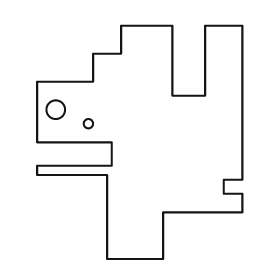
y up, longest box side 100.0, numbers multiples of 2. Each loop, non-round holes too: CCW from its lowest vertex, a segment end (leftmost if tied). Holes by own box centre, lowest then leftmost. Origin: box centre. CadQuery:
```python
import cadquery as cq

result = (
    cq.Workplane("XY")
    .moveTo(-14.0, -50.0)
    .lineTo(10.0, -50.0)
    .lineTo(10.0, -30.0)
    .lineTo(44.0, -30.0)
    .lineTo(44.0, -22.0)
    .lineTo(36.0, -22.0)
    .lineTo(36.0, -16.0)
    .lineTo(44.0, -16.0)
    .lineTo(44.0, 50.0)
    .lineTo(28.0, 50.0)
    .lineTo(28.0, 20.0)
    .lineTo(14.0, 20.0)
    .lineTo(14.0, 50.0)
    .lineTo(-8.0, 50.0)
    .lineTo(-8.0, 38.0)
    .lineTo(-20.0, 38.0)
    .lineTo(-20.0, 26.0)
    .lineTo(-44.0, 26.0)
    .lineTo(-44.0, 0.0)
    .lineTo(-12.0, 0.0)
    .lineTo(-12.0, -10.0)
    .lineTo(-44.0, -10.0)
    .lineTo(-44.0, -14.0)
    .lineTo(-14.0, -14.0)
    .close()
    .moveTo(-22.0, 8.0)
    .circle(2.0)
    .moveTo(-36.0, 14.0)
    .circle(4.0)
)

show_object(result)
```